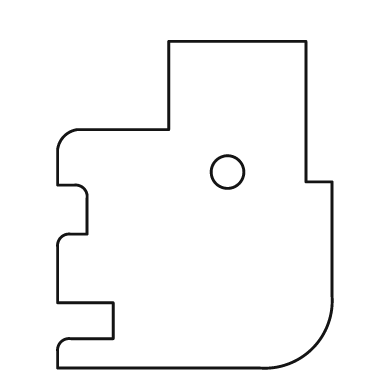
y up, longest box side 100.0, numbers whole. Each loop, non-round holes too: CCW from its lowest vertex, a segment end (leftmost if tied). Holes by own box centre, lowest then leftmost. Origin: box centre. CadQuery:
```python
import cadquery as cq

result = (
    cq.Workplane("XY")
    .moveTo(-42.0, -50.0)
    .lineTo(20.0, -50.0)
    .threePointArc((36.0, -44.0), (42.0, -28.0))
    .lineTo(42.0, 7.0)
    .lineTo(34.0, 7.0)
    .lineTo(34.0, 50.0)
    .lineTo(-8.0, 50.0)
    .lineTo(-8.0, 23.0)
    .lineTo(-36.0, 23.0)
    .threePointArc((-40.0, 21.0), (-42.0, 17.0))
    .lineTo(-42.0, 6.0)
    .lineTo(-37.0, 6.0)
    .threePointArc((-34.0, 5.0), (-33.0, 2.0))
    .lineTo(-33.0, -9.0)
    .lineTo(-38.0, -9.0)
    .threePointArc((-41.0, -10.0), (-42.0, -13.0))
    .lineTo(-42.0, -30.0)
    .lineTo(-25.0, -30.0)
    .lineTo(-25.0, -41.0)
    .lineTo(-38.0, -41.0)
    .threePointArc((-41.0, -42.0), (-42.0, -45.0))
    .close()
    .moveTo(10.0, 10.0)
    .circle(5.0)
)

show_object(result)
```